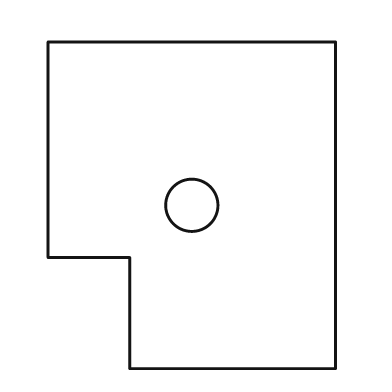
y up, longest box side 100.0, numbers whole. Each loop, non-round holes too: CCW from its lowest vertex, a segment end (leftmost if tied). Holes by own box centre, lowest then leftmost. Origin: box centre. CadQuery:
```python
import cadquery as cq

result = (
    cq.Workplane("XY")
    .moveTo(-19.0, -50.0)
    .lineTo(44.0, -50.0)
    .lineTo(44.0, 50.0)
    .lineTo(-44.0, 50.0)
    .lineTo(-44.0, -16.0)
    .lineTo(-19.0, -16.0)
    .close()
    .moveTo(0.0, 0.0)
    .circle(8.0)
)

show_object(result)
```